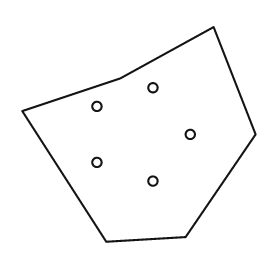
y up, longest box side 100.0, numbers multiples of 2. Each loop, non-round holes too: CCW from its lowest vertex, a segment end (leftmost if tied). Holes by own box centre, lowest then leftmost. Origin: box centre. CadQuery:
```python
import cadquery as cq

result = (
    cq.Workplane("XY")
    .moveTo(-14.0, -46.0)
    .lineTo(20.0, -44.0)
    .lineTo(50.0, 0.0)
    .lineTo(32.0, 46.0)
    .lineTo(-8.0, 24.0)
    .lineTo(-50.0, 10.0)
    .close()
    .moveTo(6.0, -20.0)
    .circle(2.0)
    .moveTo(-18.0, -12.0)
    .circle(2.0)
    .moveTo(22.0, 0.0)
    .circle(2.0)
    .moveTo(-18.0, 12.0)
    .circle(2.0)
    .moveTo(6.0, 20.0)
    .circle(2.0)
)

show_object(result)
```